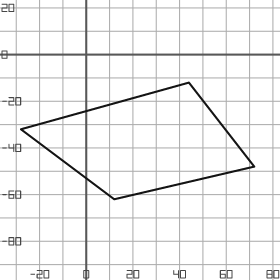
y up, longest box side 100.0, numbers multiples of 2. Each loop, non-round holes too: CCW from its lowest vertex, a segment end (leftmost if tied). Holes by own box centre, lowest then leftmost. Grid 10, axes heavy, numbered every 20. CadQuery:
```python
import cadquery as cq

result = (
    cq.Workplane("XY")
    .moveTo(12.0, -62.0)
    .lineTo(72.0, -48.0)
    .lineTo(44.0, -12.0)
    .lineTo(-28.0, -32.0)
    .close()
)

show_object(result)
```